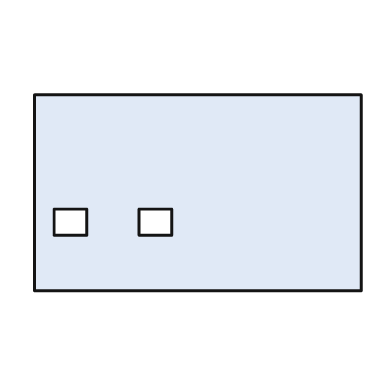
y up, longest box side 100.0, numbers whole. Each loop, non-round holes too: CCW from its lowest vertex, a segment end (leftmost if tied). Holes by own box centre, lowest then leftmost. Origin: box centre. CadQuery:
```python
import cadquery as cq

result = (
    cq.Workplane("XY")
    .moveTo(-50.0, -30.0)
    .lineTo(50.0, -30.0)
    .lineTo(50.0, 30.0)
    .lineTo(-50.0, 30.0)
    .close()
    .moveTo(-44.0, -13.0)
    .lineTo(-34.0, -13.0)
    .lineTo(-34.0, -5.0)
    .lineTo(-44.0, -5.0)
    .close()
    .moveTo(-18.0, -13.0)
    .lineTo(-8.0, -13.0)
    .lineTo(-8.0, -5.0)
    .lineTo(-18.0, -5.0)
    .close()
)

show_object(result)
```